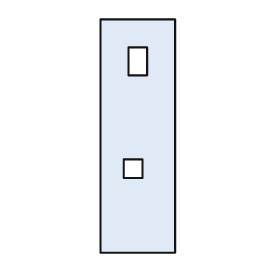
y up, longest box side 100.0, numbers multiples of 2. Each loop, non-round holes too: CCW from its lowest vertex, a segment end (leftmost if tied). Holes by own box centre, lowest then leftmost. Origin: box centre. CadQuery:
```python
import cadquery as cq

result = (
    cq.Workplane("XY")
    .moveTo(-16.0, -50.0)
    .lineTo(16.0, -50.0)
    .lineTo(16.0, 50.0)
    .lineTo(-16.0, 50.0)
    .close()
    .moveTo(-6.0, -18.0)
    .lineTo(2.0, -18.0)
    .lineTo(2.0, -10.0)
    .lineTo(-6.0, -10.0)
    .close()
    .moveTo(-4.0, 26.0)
    .lineTo(4.0, 26.0)
    .lineTo(4.0, 38.0)
    .lineTo(-4.0, 38.0)
    .close()
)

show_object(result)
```